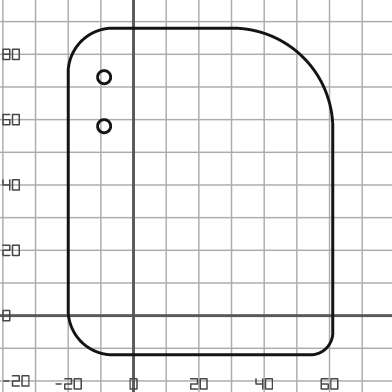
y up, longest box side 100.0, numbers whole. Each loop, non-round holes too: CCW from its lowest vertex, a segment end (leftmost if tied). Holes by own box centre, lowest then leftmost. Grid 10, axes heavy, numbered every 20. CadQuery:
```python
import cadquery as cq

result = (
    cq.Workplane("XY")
    .moveTo(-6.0, -12.0)
    .lineTo(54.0, -12.0)
    .threePointArc((59.0, -10.0), (61.0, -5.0))
    .lineTo(61.0, 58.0)
    .threePointArc((52.0, 79.0), (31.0, 88.0))
    .lineTo(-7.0, 88.0)
    .threePointArc((-16.0, 84.0), (-20.0, 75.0))
    .lineTo(-20.0, 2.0)
    .threePointArc((-16.0, -8.0), (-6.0, -12.0))
    .close()
    .moveTo(-9.0, 58.0)
    .circle(2.0)
    .moveTo(-9.0, 73.0)
    .circle(2.0)
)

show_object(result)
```